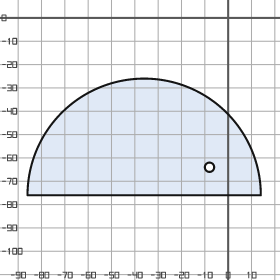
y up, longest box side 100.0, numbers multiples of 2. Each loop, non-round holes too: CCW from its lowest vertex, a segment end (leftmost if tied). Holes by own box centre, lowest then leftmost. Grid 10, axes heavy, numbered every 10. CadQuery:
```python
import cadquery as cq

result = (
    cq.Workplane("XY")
    .moveTo(-86.0, -76.0)
    .lineTo(14.0, -76.0)
    .threePointArc((-36.0, -26.0), (-86.0, -76.0))
    .close()
    .moveTo(-8.0, -64.0)
    .circle(2.0)
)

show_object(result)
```